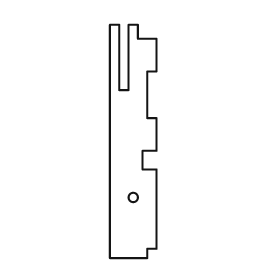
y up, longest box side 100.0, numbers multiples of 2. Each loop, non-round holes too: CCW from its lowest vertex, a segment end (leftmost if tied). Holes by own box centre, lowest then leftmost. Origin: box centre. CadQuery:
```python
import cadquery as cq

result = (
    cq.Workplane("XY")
    .moveTo(-10.0, -50.0)
    .lineTo(6.0, -50.0)
    .lineTo(6.0, -46.0)
    .lineTo(10.0, -46.0)
    .lineTo(10.0, -12.0)
    .lineTo(4.0, -12.0)
    .lineTo(4.0, -4.0)
    .lineTo(10.0, -4.0)
    .lineTo(10.0, 10.0)
    .lineTo(6.0, 10.0)
    .lineTo(6.0, 30.0)
    .lineTo(10.0, 30.0)
    .lineTo(10.0, 44.0)
    .lineTo(2.0, 44.0)
    .lineTo(2.0, 50.0)
    .lineTo(-2.0, 50.0)
    .lineTo(-2.0, 22.0)
    .lineTo(-6.0, 22.0)
    .lineTo(-6.0, 50.0)
    .lineTo(-10.0, 50.0)
    .close()
    .moveTo(0.0, -24.0)
    .circle(2.0)
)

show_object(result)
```